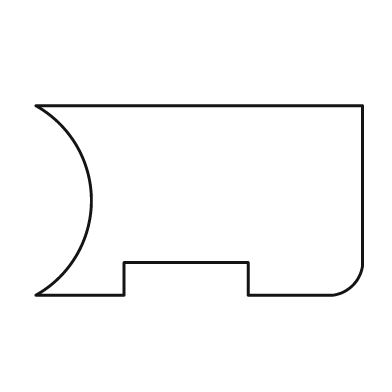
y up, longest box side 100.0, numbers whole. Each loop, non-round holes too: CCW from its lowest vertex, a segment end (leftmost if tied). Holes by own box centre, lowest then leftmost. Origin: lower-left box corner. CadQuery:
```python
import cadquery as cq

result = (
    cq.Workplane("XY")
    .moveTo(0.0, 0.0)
    .lineTo(27.0, 0.0)
    .lineTo(27.0, 10.0)
    .lineTo(65.0, 10.0)
    .lineTo(65.0, 0.0)
    .lineTo(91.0, 0.0)
    .threePointArc((97.0, 3.0), (100.0, 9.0))
    .lineTo(100.0, 58.0)
    .lineTo(0.0, 58.0)
    .threePointArc((17.0, 29.0), (0.0, 0.0))
    .close()
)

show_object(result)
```